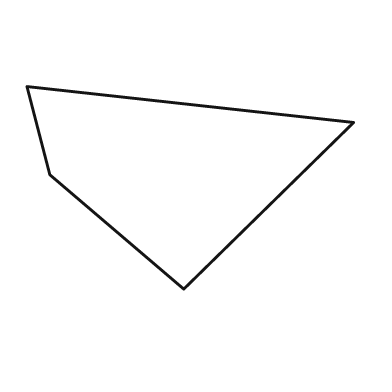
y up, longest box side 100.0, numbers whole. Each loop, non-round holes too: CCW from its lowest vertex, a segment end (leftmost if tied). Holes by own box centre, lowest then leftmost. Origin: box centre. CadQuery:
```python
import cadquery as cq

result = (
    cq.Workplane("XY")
    .moveTo(-2.0, -31.0)
    .lineTo(50.0, 20.0)
    .lineTo(-50.0, 31.0)
    .lineTo(-43.0, 4.0)
    .close()
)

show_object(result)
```